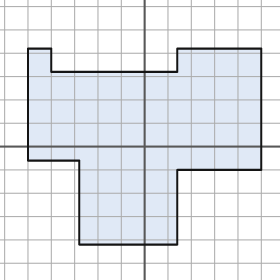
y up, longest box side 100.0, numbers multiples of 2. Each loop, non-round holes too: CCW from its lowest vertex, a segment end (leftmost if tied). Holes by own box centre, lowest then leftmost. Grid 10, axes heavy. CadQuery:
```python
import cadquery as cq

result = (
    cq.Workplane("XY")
    .moveTo(-28.0, -42.0)
    .lineTo(14.0, -42.0)
    .lineTo(14.0, -10.0)
    .lineTo(50.0, -10.0)
    .lineTo(50.0, 42.0)
    .lineTo(14.0, 42.0)
    .lineTo(14.0, 32.0)
    .lineTo(-40.0, 32.0)
    .lineTo(-40.0, 42.0)
    .lineTo(-50.0, 42.0)
    .lineTo(-50.0, -6.0)
    .lineTo(-28.0, -6.0)
    .close()
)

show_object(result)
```